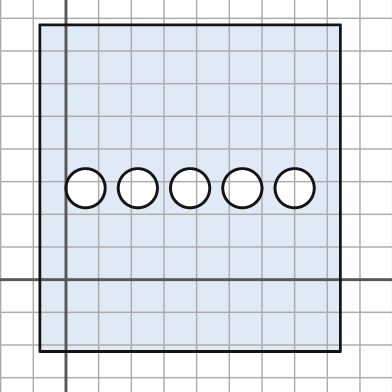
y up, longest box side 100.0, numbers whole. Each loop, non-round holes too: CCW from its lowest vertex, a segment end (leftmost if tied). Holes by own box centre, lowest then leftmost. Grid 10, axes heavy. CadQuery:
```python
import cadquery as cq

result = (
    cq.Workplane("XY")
    .moveTo(-8.0, -22.0)
    .lineTo(84.0, -22.0)
    .lineTo(84.0, 78.0)
    .lineTo(-8.0, 78.0)
    .close()
    .moveTo(6.0, 28.0)
    .circle(6.0)
    .moveTo(22.0, 28.0)
    .circle(6.0)
    .moveTo(38.0, 28.0)
    .circle(6.0)
    .moveTo(54.0, 28.0)
    .circle(6.0)
    .moveTo(70.0, 28.0)
    .circle(6.0)
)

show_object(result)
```